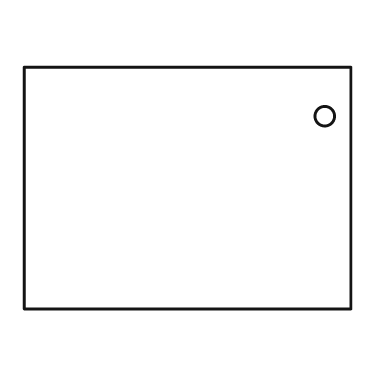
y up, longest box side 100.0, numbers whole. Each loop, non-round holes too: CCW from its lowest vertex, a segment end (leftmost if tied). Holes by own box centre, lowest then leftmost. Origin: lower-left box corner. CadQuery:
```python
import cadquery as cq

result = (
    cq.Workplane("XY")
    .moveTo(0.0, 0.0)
    .lineTo(100.0, 0.0)
    .lineTo(100.0, 74.0)
    .lineTo(0.0, 74.0)
    .close()
    .moveTo(92.0, 59.0)
    .circle(3.0)
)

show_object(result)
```